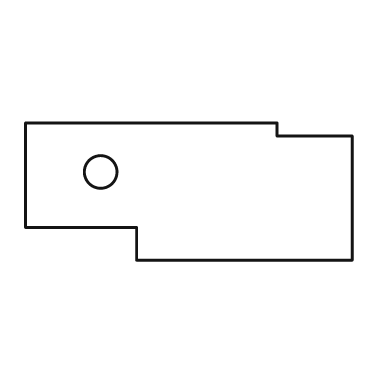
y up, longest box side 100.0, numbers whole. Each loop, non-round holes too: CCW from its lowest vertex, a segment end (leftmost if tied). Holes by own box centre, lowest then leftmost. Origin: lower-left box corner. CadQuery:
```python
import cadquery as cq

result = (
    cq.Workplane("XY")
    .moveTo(34.0, 0.0)
    .lineTo(100.0, 0.0)
    .lineTo(100.0, 38.0)
    .lineTo(77.0, 38.0)
    .lineTo(77.0, 42.0)
    .lineTo(0.0, 42.0)
    .lineTo(0.0, 10.0)
    .lineTo(34.0, 10.0)
    .close()
    .moveTo(23.0, 27.0)
    .circle(5.0)
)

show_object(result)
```